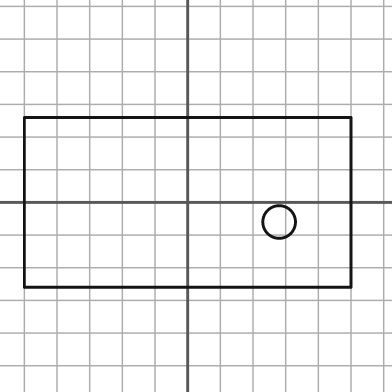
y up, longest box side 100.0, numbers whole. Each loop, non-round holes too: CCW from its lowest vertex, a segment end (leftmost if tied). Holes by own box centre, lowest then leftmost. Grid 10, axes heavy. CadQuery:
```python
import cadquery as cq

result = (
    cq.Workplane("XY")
    .moveTo(-50.0, -26.0)
    .lineTo(50.0, -26.0)
    .lineTo(50.0, 26.0)
    .lineTo(-50.0, 26.0)
    .close()
    .moveTo(28.0, -6.0)
    .circle(5.0)
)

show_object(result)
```